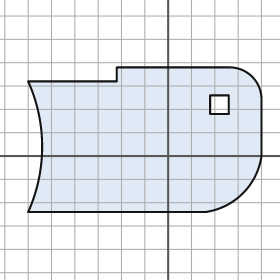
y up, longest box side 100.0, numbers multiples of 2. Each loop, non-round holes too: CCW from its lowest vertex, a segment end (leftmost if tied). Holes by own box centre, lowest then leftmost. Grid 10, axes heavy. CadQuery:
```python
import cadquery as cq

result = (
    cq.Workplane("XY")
    .moveTo(-60.0, -24.0)
    .lineTo(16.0, -24.0)
    .threePointArc((32.0, -16.0), (40.0, 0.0))
    .lineTo(40.0, 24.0)
    .threePointArc((36.0, 34.0), (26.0, 38.0))
    .lineTo(-22.0, 38.0)
    .lineTo(-22.0, 32.0)
    .lineTo(-60.0, 32.0)
    .threePointArc((-54.0, 4.0), (-60.0, -24.0))
    .close()
    .moveTo(18.0, 18.0)
    .lineTo(26.0, 18.0)
    .lineTo(26.0, 26.0)
    .lineTo(18.0, 26.0)
    .close()
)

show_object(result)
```